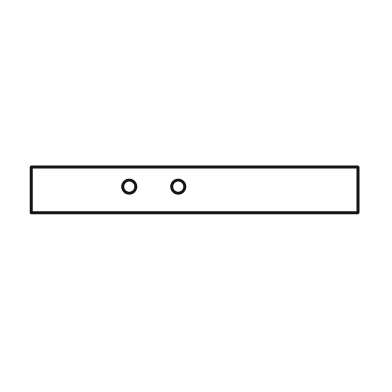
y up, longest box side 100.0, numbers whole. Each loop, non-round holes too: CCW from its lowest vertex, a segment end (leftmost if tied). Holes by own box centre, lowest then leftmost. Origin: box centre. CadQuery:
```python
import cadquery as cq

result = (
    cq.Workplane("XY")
    .moveTo(-50.0, -7.0)
    .lineTo(50.0, -7.0)
    .lineTo(50.0, 7.0)
    .lineTo(-50.0, 7.0)
    .close()
    .moveTo(-20.0, 1.0)
    .circle(2.0)
    .moveTo(-5.0, 1.0)
    .circle(2.0)
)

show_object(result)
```